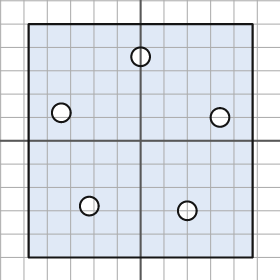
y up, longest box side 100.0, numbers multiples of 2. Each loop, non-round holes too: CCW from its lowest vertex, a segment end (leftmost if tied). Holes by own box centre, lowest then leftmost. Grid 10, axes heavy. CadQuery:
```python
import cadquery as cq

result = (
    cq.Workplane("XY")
    .moveTo(-48.0, -50.0)
    .lineTo(48.0, -50.0)
    .lineTo(48.0, 50.0)
    .lineTo(-48.0, 50.0)
    .close()
    .moveTo(20.0, -30.0)
    .circle(4.0)
    .moveTo(-22.0, -28.0)
    .circle(4.0)
    .moveTo(34.0, 10.0)
    .circle(4.0)
    .moveTo(-34.0, 12.0)
    .circle(4.0)
    .moveTo(0.0, 36.0)
    .circle(4.0)
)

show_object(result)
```